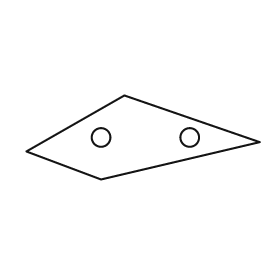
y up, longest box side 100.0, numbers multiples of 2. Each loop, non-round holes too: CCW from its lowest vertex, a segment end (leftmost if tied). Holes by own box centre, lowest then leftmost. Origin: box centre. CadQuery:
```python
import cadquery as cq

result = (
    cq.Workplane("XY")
    .moveTo(-18.0, -18.0)
    .lineTo(50.0, -2.0)
    .lineTo(-8.0, 18.0)
    .lineTo(-50.0, -6.0)
    .close()
    .moveTo(-18.0, 0.0)
    .circle(4.0)
    .moveTo(20.0, 0.0)
    .circle(4.0)
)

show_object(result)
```